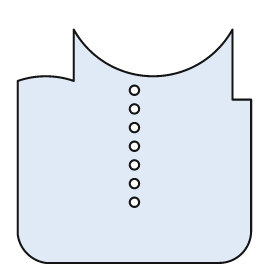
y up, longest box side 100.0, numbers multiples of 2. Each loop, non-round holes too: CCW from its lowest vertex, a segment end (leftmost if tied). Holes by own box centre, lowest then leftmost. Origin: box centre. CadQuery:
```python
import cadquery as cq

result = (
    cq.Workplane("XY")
    .moveTo(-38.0, -50.0)
    .lineTo(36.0, -50.0)
    .threePointArc((46.0, -46.0), (50.0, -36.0))
    .lineTo(50.0, 20.0)
    .lineTo(42.0, 20.0)
    .lineTo(42.0, 50.0)
    .threePointArc((8.0, 30.0), (-26.0, 50.0))
    .lineTo(-26.0, 28.0)
    .threePointArc((-38.0, 30.0), (-50.0, 28.0))
    .lineTo(-50.0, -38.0)
    .threePointArc((-46.0, -46.0), (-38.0, -50.0))
    .close()
    .moveTo(0.0, -24.0)
    .circle(2.0)
    .moveTo(0.0, -16.0)
    .circle(2.0)
    .moveTo(0.0, -8.0)
    .circle(2.0)
    .moveTo(0.0, 0.0)
    .circle(2.0)
    .moveTo(0.0, 8.0)
    .circle(2.0)
    .moveTo(0.0, 16.0)
    .circle(2.0)
    .moveTo(0.0, 24.0)
    .circle(2.0)
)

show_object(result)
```